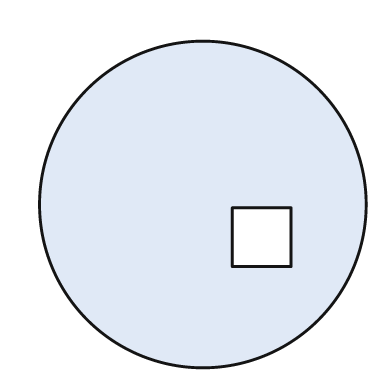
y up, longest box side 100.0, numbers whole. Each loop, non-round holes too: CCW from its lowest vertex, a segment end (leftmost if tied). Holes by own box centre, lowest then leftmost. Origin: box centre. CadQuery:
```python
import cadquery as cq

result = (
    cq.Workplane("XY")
    .moveTo(0.0, 0.0)
    .circle(50.0)
    .moveTo(9.0, -19.0)
    .lineTo(27.0, -19.0)
    .lineTo(27.0, -1.0)
    .lineTo(9.0, -1.0)
    .close()
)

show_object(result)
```